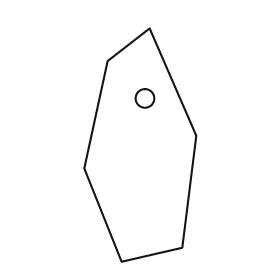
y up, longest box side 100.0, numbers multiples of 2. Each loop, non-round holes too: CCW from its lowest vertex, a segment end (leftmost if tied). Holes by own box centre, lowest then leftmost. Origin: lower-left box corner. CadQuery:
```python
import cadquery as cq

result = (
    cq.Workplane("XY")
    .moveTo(16.0, 0.0)
    .lineTo(42.0, 6.0)
    .lineTo(48.0, 54.0)
    .lineTo(28.0, 100.0)
    .lineTo(10.0, 86.0)
    .lineTo(0.0, 40.0)
    .close()
    .moveTo(26.0, 70.0)
    .circle(4.0)
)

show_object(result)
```